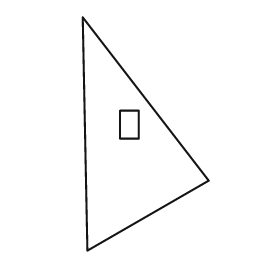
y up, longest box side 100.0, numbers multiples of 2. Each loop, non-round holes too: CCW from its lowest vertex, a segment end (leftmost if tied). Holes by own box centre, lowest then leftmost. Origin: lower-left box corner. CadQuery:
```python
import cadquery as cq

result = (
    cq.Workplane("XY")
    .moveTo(2.0, 0.0)
    .lineTo(54.0, 30.0)
    .lineTo(0.0, 100.0)
    .close()
    .moveTo(16.0, 48.0)
    .lineTo(24.0, 48.0)
    .lineTo(24.0, 60.0)
    .lineTo(16.0, 60.0)
    .close()
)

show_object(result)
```